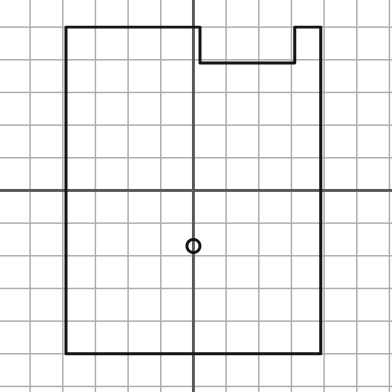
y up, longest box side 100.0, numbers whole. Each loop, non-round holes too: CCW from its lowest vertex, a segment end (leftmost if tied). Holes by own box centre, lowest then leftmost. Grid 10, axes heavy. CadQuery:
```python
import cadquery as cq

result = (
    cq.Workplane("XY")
    .moveTo(-39.0, -50.0)
    .lineTo(39.0, -50.0)
    .lineTo(39.0, 50.0)
    .lineTo(31.0, 50.0)
    .lineTo(31.0, 39.0)
    .lineTo(2.0, 39.0)
    .lineTo(2.0, 50.0)
    .lineTo(-39.0, 50.0)
    .close()
    .moveTo(0.0, -17.0)
    .circle(2.0)
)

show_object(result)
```